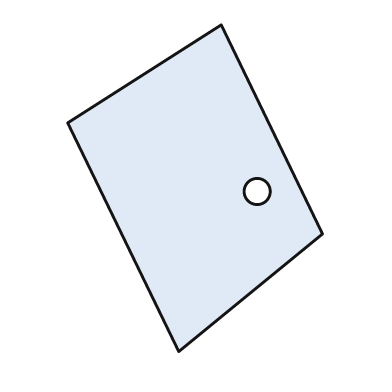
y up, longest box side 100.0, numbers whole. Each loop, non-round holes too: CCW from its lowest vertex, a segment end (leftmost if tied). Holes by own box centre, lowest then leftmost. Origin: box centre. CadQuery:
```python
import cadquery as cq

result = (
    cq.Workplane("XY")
    .moveTo(-5.0, -50.0)
    .lineTo(39.0, -14.0)
    .lineTo(8.0, 50.0)
    .lineTo(-39.0, 20.0)
    .close()
    .moveTo(19.0, -1.0)
    .circle(4.0)
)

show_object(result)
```